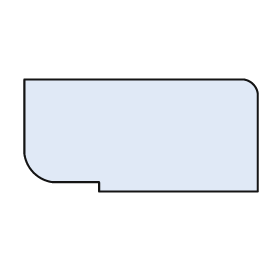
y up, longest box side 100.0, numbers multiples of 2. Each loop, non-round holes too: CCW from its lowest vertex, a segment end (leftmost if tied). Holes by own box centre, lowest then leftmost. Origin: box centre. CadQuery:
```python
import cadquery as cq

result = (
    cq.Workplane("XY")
    .moveTo(-18.0, -24.0)
    .lineTo(50.0, -24.0)
    .lineTo(50.0, 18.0)
    .threePointArc((48.0, 22.0), (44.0, 24.0))
    .lineTo(-50.0, 24.0)
    .lineTo(-50.0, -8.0)
    .threePointArc((-46.0, -16.0), (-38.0, -20.0))
    .lineTo(-18.0, -20.0)
    .close()
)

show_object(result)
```